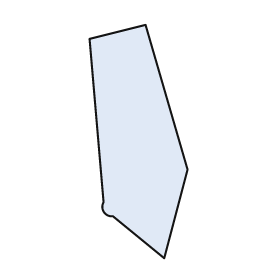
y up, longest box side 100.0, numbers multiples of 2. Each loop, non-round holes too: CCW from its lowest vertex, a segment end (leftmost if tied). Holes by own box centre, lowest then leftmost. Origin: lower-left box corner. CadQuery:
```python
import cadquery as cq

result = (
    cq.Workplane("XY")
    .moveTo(32.0, 0.0)
    .lineTo(42.0, 38.0)
    .lineTo(24.0, 100.0)
    .lineTo(0.0, 94.0)
    .lineTo(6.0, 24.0)
    .threePointArc((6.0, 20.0), (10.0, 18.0))
    .close()
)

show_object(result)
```